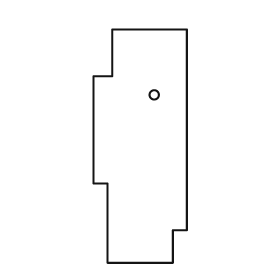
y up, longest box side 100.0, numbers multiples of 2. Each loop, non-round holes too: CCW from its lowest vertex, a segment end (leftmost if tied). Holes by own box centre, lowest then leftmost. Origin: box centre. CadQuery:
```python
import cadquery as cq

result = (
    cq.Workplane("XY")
    .moveTo(-14.0, -50.0)
    .lineTo(14.0, -50.0)
    .lineTo(14.0, -36.0)
    .lineTo(20.0, -36.0)
    .lineTo(20.0, 50.0)
    .lineTo(-12.0, 50.0)
    .lineTo(-12.0, 30.0)
    .lineTo(-20.0, 30.0)
    .lineTo(-20.0, -16.0)
    .lineTo(-14.0, -16.0)
    .close()
    .moveTo(6.0, 22.0)
    .circle(2.0)
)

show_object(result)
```